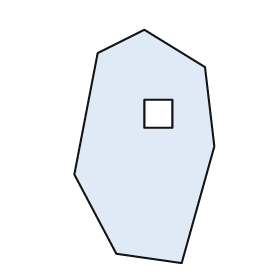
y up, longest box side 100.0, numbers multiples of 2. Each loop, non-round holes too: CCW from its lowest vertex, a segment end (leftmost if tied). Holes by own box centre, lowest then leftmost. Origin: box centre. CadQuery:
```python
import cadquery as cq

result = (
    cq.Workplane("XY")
    .moveTo(16.0, -50.0)
    .lineTo(30.0, 0.0)
    .lineTo(26.0, 34.0)
    .lineTo(0.0, 50.0)
    .lineTo(-20.0, 40.0)
    .lineTo(-30.0, -12.0)
    .lineTo(-12.0, -46.0)
    .close()
    .moveTo(0.0, 8.0)
    .lineTo(12.0, 8.0)
    .lineTo(12.0, 20.0)
    .lineTo(0.0, 20.0)
    .close()
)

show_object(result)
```